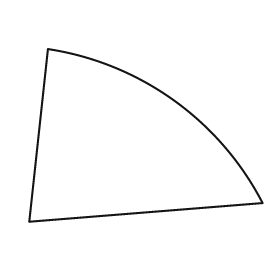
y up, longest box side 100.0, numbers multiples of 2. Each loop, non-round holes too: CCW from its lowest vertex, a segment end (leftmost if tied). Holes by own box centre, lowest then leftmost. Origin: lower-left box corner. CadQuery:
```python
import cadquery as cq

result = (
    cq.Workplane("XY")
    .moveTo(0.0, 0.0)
    .lineTo(100.0, 8.0)
    .threePointArc((62.0, 52.0), (8.0, 74.0))
    .close()
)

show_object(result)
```